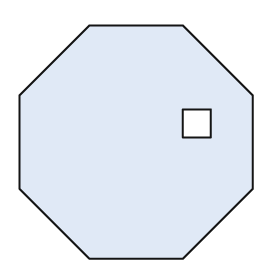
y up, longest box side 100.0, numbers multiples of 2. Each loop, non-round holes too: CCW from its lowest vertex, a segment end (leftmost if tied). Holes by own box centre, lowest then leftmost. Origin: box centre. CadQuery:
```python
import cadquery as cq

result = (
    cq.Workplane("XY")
    .moveTo(-20.0, -50.0)
    .lineTo(20.0, -50.0)
    .lineTo(50.0, -20.0)
    .lineTo(50.0, 20.0)
    .lineTo(20.0, 50.0)
    .lineTo(-20.0, 50.0)
    .lineTo(-50.0, 20.0)
    .lineTo(-50.0, -20.0)
    .close()
    .moveTo(20.0, 2.0)
    .lineTo(32.0, 2.0)
    .lineTo(32.0, 14.0)
    .lineTo(20.0, 14.0)
    .close()
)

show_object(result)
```